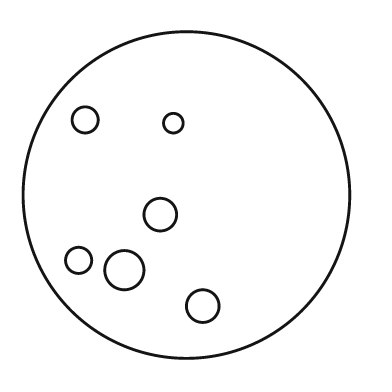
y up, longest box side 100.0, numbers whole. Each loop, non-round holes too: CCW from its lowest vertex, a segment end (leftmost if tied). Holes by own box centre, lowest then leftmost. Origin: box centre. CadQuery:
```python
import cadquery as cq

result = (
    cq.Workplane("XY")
    .moveTo(0.0, 0.0)
    .circle(50.0)
    .moveTo(5.0, -34.0)
    .circle(5.0)
    .moveTo(-19.0, -23.0)
    .circle(6.0)
    .moveTo(-33.0, -20.0)
    .circle(4.0)
    .moveTo(-8.0, -6.0)
    .circle(5.0)
    .moveTo(-4.0, 22.0)
    .circle(3.0)
    .moveTo(-31.0, 23.0)
    .circle(4.0)
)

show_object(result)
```